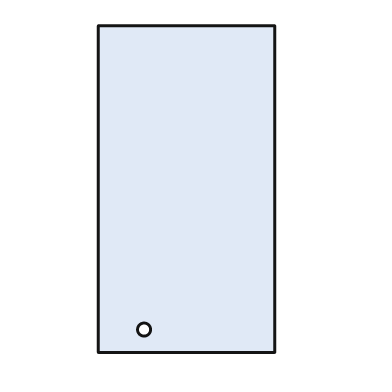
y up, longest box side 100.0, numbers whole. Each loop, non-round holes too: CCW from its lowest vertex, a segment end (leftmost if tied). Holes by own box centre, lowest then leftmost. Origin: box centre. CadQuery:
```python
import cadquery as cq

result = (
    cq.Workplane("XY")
    .moveTo(-27.0, -50.0)
    .lineTo(27.0, -50.0)
    .lineTo(27.0, 50.0)
    .lineTo(-27.0, 50.0)
    .close()
    .moveTo(-13.0, -43.0)
    .circle(2.0)
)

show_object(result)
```